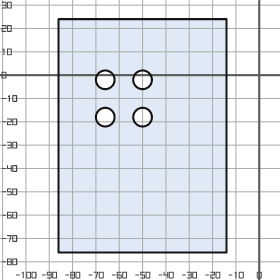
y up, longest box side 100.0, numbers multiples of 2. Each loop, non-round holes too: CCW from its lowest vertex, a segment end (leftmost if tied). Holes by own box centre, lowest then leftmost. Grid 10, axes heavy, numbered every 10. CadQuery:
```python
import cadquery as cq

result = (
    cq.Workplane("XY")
    .moveTo(-86.0, -76.0)
    .lineTo(-14.0, -76.0)
    .lineTo(-14.0, 24.0)
    .lineTo(-86.0, 24.0)
    .close()
    .moveTo(-66.0, -18.0)
    .circle(4.0)
    .moveTo(-50.0, -18.0)
    .circle(4.0)
    .moveTo(-66.0, -2.0)
    .circle(4.0)
    .moveTo(-50.0, -2.0)
    .circle(4.0)
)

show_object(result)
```